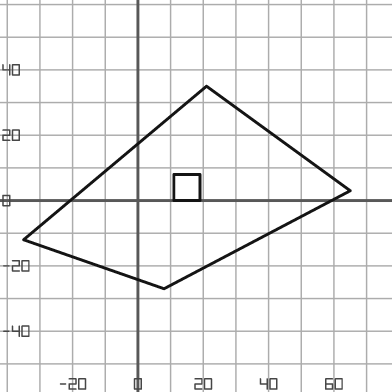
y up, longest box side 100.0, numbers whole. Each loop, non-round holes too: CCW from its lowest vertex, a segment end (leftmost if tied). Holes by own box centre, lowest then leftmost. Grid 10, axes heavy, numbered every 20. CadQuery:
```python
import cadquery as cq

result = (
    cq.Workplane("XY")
    .moveTo(8.0, -27.0)
    .lineTo(65.0, 3.0)
    .lineTo(21.0, 35.0)
    .lineTo(-35.0, -12.0)
    .close()
    .moveTo(11.0, 0.0)
    .lineTo(19.0, 0.0)
    .lineTo(19.0, 8.0)
    .lineTo(11.0, 8.0)
    .close()
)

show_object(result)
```